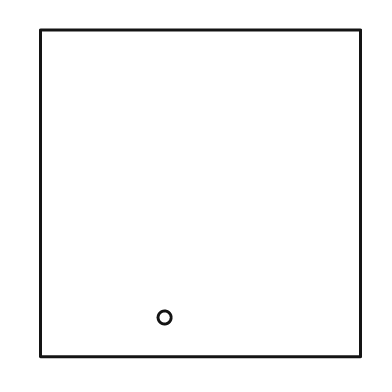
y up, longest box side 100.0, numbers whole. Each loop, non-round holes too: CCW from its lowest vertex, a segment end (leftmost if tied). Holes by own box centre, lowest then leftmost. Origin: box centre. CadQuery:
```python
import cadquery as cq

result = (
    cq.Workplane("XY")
    .moveTo(-49.0, -50.0)
    .lineTo(49.0, -50.0)
    .lineTo(49.0, 50.0)
    .lineTo(-49.0, 50.0)
    .close()
    .moveTo(-11.0, -38.0)
    .circle(2.0)
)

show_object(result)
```